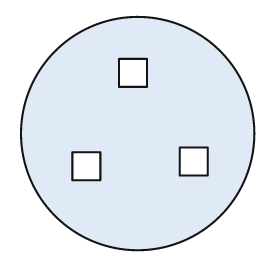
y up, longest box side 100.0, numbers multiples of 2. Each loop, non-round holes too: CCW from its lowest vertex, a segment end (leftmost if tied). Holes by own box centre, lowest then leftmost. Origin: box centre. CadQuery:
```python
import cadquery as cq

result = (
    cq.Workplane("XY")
    .moveTo(0.0, 0.0)
    .circle(50.0)
    .moveTo(-28.0, -20.0)
    .lineTo(-16.0, -20.0)
    .lineTo(-16.0, -8.0)
    .lineTo(-28.0, -8.0)
    .close()
    .moveTo(18.0, -18.0)
    .lineTo(30.0, -18.0)
    .lineTo(30.0, -6.0)
    .lineTo(18.0, -6.0)
    .close()
    .moveTo(-8.0, 20.0)
    .lineTo(4.0, 20.0)
    .lineTo(4.0, 32.0)
    .lineTo(-8.0, 32.0)
    .close()
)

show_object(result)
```